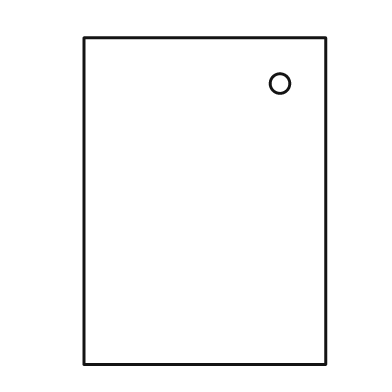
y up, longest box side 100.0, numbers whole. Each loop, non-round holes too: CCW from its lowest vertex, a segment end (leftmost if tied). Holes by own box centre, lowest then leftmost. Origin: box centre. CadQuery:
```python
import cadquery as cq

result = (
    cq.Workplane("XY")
    .moveTo(-37.0, -50.0)
    .lineTo(37.0, -50.0)
    .lineTo(37.0, 50.0)
    .lineTo(-37.0, 50.0)
    .close()
    .moveTo(23.0, 36.0)
    .circle(3.0)
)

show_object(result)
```